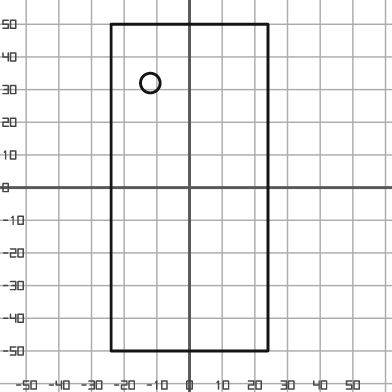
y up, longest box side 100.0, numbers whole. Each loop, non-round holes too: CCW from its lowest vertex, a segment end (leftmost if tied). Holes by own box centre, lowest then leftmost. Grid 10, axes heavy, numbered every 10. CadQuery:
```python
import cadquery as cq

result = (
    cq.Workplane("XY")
    .moveTo(-24.0, -50.0)
    .lineTo(24.0, -50.0)
    .lineTo(24.0, 50.0)
    .lineTo(-24.0, 50.0)
    .close()
    .moveTo(-12.0, 32.0)
    .circle(3.0)
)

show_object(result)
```